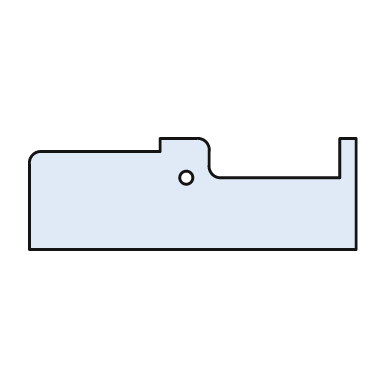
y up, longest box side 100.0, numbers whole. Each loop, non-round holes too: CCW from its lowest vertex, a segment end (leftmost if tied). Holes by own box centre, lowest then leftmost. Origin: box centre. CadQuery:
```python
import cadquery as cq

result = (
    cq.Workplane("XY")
    .moveTo(-50.0, -17.0)
    .lineTo(50.0, -17.0)
    .lineTo(50.0, 17.0)
    .lineTo(45.0, 17.0)
    .lineTo(45.0, 5.0)
    .lineTo(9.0, 5.0)
    .threePointArc((6.0, 6.0), (5.0, 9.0))
    .lineTo(5.0, 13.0)
    .threePointArc((4.0, 16.0), (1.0, 17.0))
    .lineTo(-10.0, 17.0)
    .lineTo(-10.0, 13.0)
    .lineTo(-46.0, 13.0)
    .threePointArc((-49.0, 12.0), (-50.0, 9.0))
    .close()
    .moveTo(-2.0, 5.0)
    .circle(2.0)
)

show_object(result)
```